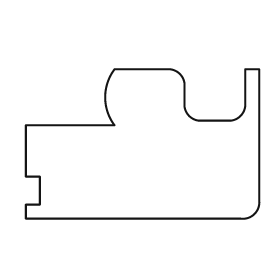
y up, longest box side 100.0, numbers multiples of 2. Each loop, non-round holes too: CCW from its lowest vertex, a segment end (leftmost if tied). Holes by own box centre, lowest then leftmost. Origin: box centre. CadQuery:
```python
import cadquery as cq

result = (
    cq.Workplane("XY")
    .moveTo(-50.0, -32.0)
    .lineTo(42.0, -32.0)
    .threePointArc((48.0, -30.0), (50.0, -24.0))
    .lineTo(50.0, 32.0)
    .lineTo(44.0, 32.0)
    .lineTo(44.0, 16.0)
    .threePointArc((42.0, 12.0), (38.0, 10.0))
    .lineTo(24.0, 10.0)
    .threePointArc((20.0, 12.0), (18.0, 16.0))
    .lineTo(18.0, 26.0)
    .threePointArc((16.0, 30.0), (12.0, 32.0))
    .lineTo(-12.0, 32.0)
    .threePointArc((-16.0, 20.0), (-12.0, 8.0))
    .lineTo(-50.0, 8.0)
    .lineTo(-50.0, -14.0)
    .lineTo(-44.0, -14.0)
    .lineTo(-44.0, -26.0)
    .lineTo(-50.0, -26.0)
    .close()
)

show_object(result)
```